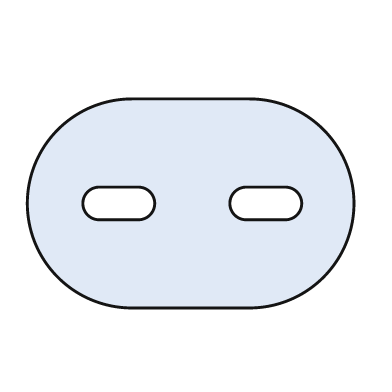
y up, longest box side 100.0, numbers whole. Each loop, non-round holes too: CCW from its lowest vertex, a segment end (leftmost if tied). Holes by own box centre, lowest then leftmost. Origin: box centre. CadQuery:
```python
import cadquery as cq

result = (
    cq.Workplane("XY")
    .moveTo(-18.0, -32.0)
    .lineTo(18.0, -32.0)
    .threePointArc((50.0, 0.0), (18.0, 32.0))
    .lineTo(-18.0, 32.0)
    .threePointArc((-50.0, 0.0), (-18.0, -32.0))
    .close()
    .moveTo(-28.0, -5.0)
    .lineTo(-16.0, -5.0)
    .threePointArc((-11.0, 0.0), (-16.0, 5.0))
    .lineTo(-28.0, 5.0)
    .threePointArc((-33.0, 0.0), (-28.0, -5.0))
    .close()
    .moveTo(17.0, -5.0)
    .lineTo(29.0, -5.0)
    .threePointArc((34.0, 0.0), (29.0, 5.0))
    .lineTo(17.0, 5.0)
    .threePointArc((12.0, 0.0), (17.0, -5.0))
    .close()
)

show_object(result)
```